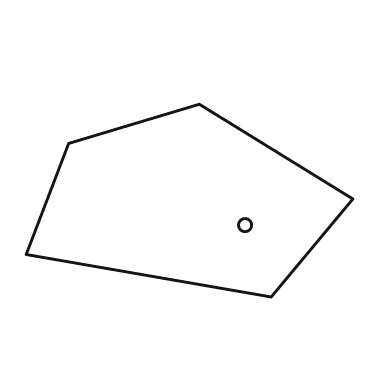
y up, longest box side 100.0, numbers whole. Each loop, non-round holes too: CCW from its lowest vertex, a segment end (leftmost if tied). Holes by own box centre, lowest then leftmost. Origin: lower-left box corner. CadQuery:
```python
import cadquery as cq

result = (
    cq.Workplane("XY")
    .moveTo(75.0, 0.0)
    .lineTo(100.0, 30.0)
    .lineTo(53.0, 59.0)
    .lineTo(13.0, 47.0)
    .lineTo(0.0, 13.0)
    .close()
    .moveTo(67.0, 22.0)
    .circle(2.0)
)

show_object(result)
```